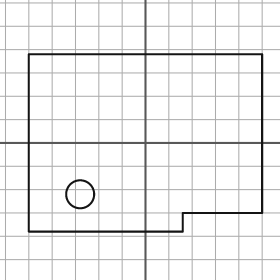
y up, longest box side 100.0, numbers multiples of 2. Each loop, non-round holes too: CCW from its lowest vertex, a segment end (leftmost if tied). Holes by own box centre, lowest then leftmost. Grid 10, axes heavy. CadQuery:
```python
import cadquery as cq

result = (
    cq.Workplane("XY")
    .moveTo(-50.0, -38.0)
    .lineTo(16.0, -38.0)
    .lineTo(16.0, -30.0)
    .lineTo(50.0, -30.0)
    .lineTo(50.0, 38.0)
    .lineTo(-50.0, 38.0)
    .close()
    .moveTo(-28.0, -22.0)
    .circle(6.0)
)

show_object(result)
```